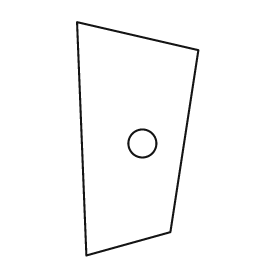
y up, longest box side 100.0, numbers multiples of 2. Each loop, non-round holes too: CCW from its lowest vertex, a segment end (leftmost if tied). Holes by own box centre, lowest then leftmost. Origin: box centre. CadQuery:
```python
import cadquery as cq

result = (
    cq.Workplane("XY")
    .moveTo(-22.0, -50.0)
    .lineTo(14.0, -40.0)
    .lineTo(26.0, 38.0)
    .lineTo(-26.0, 50.0)
    .close()
    .moveTo(2.0, -2.0)
    .circle(6.0)
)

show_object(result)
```